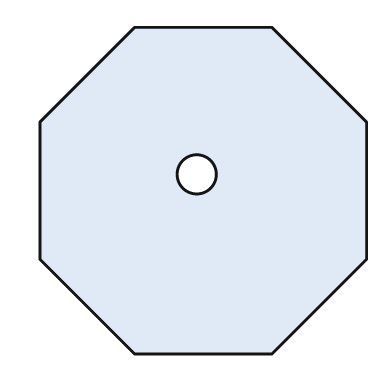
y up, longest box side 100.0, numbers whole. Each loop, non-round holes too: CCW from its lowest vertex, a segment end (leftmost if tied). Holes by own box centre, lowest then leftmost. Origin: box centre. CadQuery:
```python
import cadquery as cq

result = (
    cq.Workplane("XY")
    .moveTo(-21.0, -50.0)
    .lineTo(21.0, -50.0)
    .lineTo(50.0, -21.0)
    .lineTo(50.0, 21.0)
    .lineTo(21.0, 50.0)
    .lineTo(-21.0, 50.0)
    .lineTo(-50.0, 21.0)
    .lineTo(-50.0, -21.0)
    .close()
    .moveTo(-2.0, 5.0)
    .circle(6.0)
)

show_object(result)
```